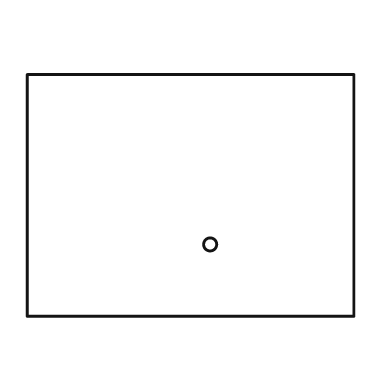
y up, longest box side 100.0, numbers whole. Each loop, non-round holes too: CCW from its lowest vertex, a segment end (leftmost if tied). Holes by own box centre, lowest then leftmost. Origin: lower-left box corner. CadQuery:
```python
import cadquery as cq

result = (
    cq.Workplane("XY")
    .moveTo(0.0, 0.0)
    .lineTo(100.0, 0.0)
    .lineTo(100.0, 74.0)
    .lineTo(0.0, 74.0)
    .close()
    .moveTo(56.0, 22.0)
    .circle(2.0)
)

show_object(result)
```